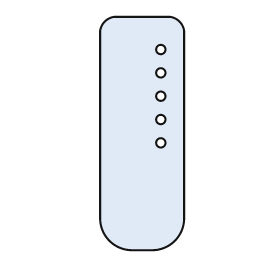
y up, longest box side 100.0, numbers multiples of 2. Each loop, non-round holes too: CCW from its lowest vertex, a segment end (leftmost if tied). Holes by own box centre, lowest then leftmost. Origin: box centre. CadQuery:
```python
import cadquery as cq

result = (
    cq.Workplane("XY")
    .moveTo(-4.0, -50.0)
    .lineTo(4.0, -50.0)
    .threePointArc((14.0, -46.0), (18.0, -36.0))
    .lineTo(18.0, 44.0)
    .threePointArc((16.0, 48.0), (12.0, 50.0))
    .lineTo(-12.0, 50.0)
    .threePointArc((-16.0, 48.0), (-18.0, 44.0))
    .lineTo(-18.0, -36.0)
    .threePointArc((-14.0, -46.0), (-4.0, -50.0))
    .close()
    .moveTo(8.0, -4.0)
    .circle(2.0)
    .moveTo(8.0, 6.0)
    .circle(2.0)
    .moveTo(8.0, 16.0)
    .circle(2.0)
    .moveTo(8.0, 26.0)
    .circle(2.0)
    .moveTo(8.0, 36.0)
    .circle(2.0)
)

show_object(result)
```